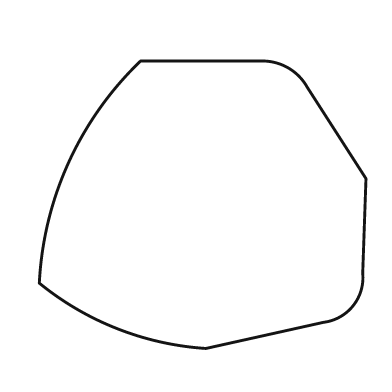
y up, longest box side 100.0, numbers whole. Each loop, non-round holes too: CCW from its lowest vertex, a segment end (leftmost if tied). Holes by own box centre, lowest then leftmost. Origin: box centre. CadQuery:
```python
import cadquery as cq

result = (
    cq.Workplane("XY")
    .moveTo(1.0, -44.0)
    .lineTo(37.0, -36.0)
    .threePointArc((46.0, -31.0), (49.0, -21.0))
    .lineTo(50.0, 8.0)
    .lineTo(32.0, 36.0)
    .threePointArc((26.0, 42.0), (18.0, 44.0))
    .lineTo(-19.0, 44.0)
    .threePointArc((-41.0, 13.0), (-50.0, -24.0))
    .threePointArc((-26.0, -38.0), (1.0, -44.0))
    .close()
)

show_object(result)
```